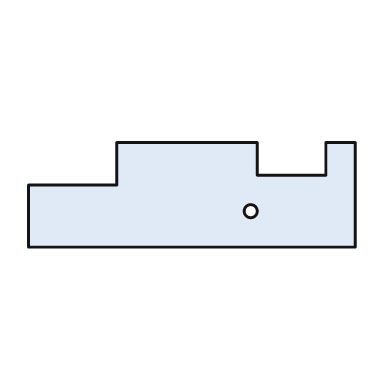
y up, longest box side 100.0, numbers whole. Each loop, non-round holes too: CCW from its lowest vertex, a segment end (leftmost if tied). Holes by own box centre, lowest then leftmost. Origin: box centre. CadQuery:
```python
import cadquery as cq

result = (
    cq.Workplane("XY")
    .moveTo(-50.0, -16.0)
    .lineTo(50.0, -16.0)
    .lineTo(50.0, 16.0)
    .lineTo(41.0, 16.0)
    .lineTo(41.0, 6.0)
    .lineTo(20.0, 6.0)
    .lineTo(20.0, 16.0)
    .lineTo(-23.0, 16.0)
    .lineTo(-23.0, 3.0)
    .lineTo(-50.0, 3.0)
    .close()
    .moveTo(18.0, -5.0)
    .circle(2.0)
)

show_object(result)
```